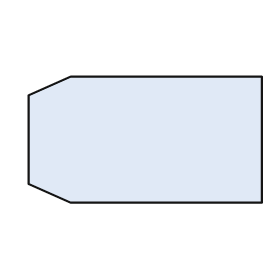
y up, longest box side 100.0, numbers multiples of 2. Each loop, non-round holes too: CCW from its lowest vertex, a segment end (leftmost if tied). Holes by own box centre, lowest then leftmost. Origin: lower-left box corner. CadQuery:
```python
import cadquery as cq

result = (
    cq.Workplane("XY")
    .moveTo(18.0, 0.0)
    .lineTo(100.0, 0.0)
    .lineTo(100.0, 54.0)
    .lineTo(18.0, 54.0)
    .lineTo(0.0, 46.0)
    .lineTo(0.0, 8.0)
    .close()
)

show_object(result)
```